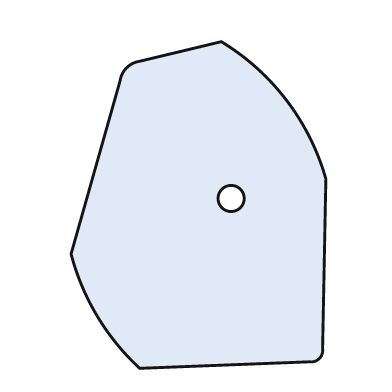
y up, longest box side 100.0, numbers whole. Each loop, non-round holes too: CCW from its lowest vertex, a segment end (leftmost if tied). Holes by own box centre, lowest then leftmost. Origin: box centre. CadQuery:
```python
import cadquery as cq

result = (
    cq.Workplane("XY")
    .moveTo(-18.0, -50.0)
    .lineTo(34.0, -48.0)
    .threePointArc((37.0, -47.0), (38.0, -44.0))
    .lineTo(39.0, 8.0)
    .threePointArc((27.0, 32.0), (7.0, 50.0))
    .lineTo(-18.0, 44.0)
    .threePointArc((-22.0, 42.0), (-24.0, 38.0))
    .lineTo(-39.0, -15.0)
    .threePointArc((-31.0, -34.0), (-18.0, -50.0))
    .close()
    .moveTo(10.0, 2.0)
    .circle(4.0)
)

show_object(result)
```